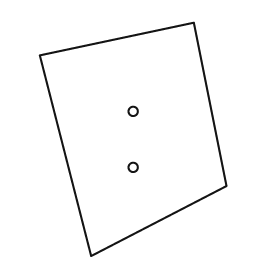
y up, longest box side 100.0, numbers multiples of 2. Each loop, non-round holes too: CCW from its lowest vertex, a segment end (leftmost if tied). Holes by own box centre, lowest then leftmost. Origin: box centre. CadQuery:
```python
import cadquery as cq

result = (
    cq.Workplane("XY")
    .moveTo(-18.0, -50.0)
    .lineTo(40.0, -20.0)
    .lineTo(26.0, 50.0)
    .lineTo(-40.0, 36.0)
    .close()
    .moveTo(0.0, -12.0)
    .circle(2.0)
    .moveTo(0.0, 12.0)
    .circle(2.0)
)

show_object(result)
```